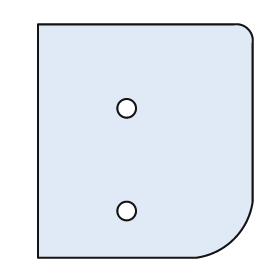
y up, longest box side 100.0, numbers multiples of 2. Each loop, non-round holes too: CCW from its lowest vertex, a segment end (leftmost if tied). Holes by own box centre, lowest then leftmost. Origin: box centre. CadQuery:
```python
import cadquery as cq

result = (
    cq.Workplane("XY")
    .moveTo(-46.0, -50.0)
    .lineTo(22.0, -50.0)
    .threePointArc((38.0, -42.0), (46.0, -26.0))
    .lineTo(46.0, 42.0)
    .threePointArc((44.0, 48.0), (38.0, 50.0))
    .lineTo(-46.0, 50.0)
    .close()
    .moveTo(-8.0, -30.0)
    .circle(4.0)
    .moveTo(-8.0, 14.0)
    .circle(4.0)
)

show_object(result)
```